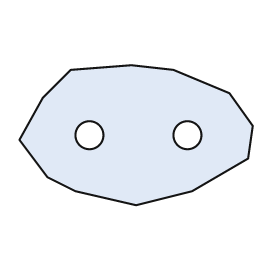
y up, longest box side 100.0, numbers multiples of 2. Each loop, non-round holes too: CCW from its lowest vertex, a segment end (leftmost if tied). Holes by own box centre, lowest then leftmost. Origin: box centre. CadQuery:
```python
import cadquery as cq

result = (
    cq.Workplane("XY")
    .moveTo(0.0, -30.0)
    .lineTo(24.0, -24.0)
    .lineTo(48.0, -10.0)
    .lineTo(50.0, 4.0)
    .lineTo(40.0, 18.0)
    .lineTo(16.0, 28.0)
    .lineTo(-2.0, 30.0)
    .lineTo(-28.0, 28.0)
    .lineTo(-40.0, 16.0)
    .lineTo(-50.0, -2.0)
    .lineTo(-38.0, -18.0)
    .lineTo(-26.0, -24.0)
    .close()
    .moveTo(-20.0, 0.0)
    .circle(6.0)
    .moveTo(22.0, 0.0)
    .circle(6.0)
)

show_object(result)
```